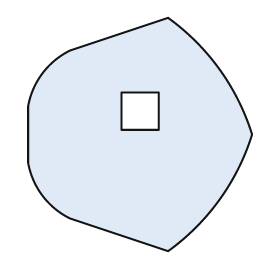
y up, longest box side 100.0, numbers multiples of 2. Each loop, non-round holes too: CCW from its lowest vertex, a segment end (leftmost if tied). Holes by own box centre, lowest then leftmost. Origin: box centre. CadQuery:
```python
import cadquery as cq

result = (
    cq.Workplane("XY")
    .moveTo(12.0, -50.0)
    .threePointArc((34.0, -28.0), (48.0, 0.0))
    .threePointArc((34.0, 28.0), (12.0, 50.0))
    .lineTo(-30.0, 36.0)
    .threePointArc((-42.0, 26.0), (-48.0, 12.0))
    .lineTo(-48.0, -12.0)
    .threePointArc((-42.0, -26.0), (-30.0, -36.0))
    .close()
    .moveTo(-8.0, 2.0)
    .lineTo(8.0, 2.0)
    .lineTo(8.0, 18.0)
    .lineTo(-8.0, 18.0)
    .close()
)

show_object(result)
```